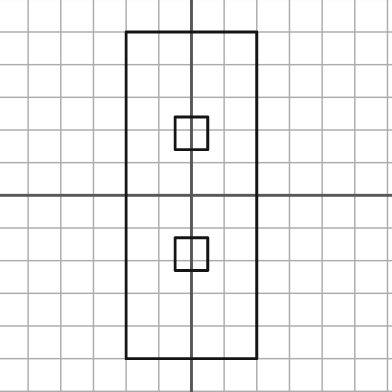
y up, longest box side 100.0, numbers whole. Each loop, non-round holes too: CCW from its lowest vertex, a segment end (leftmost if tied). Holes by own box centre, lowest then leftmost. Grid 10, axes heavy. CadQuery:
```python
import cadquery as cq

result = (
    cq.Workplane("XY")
    .moveTo(-20.0, -50.0)
    .lineTo(20.0, -50.0)
    .lineTo(20.0, 50.0)
    .lineTo(-20.0, 50.0)
    .close()
    .moveTo(-5.0, -23.0)
    .lineTo(5.0, -23.0)
    .lineTo(5.0, -13.0)
    .lineTo(-5.0, -13.0)
    .close()
    .moveTo(-5.0, 14.0)
    .lineTo(5.0, 14.0)
    .lineTo(5.0, 24.0)
    .lineTo(-5.0, 24.0)
    .close()
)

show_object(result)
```